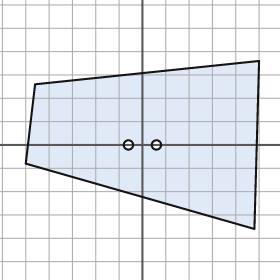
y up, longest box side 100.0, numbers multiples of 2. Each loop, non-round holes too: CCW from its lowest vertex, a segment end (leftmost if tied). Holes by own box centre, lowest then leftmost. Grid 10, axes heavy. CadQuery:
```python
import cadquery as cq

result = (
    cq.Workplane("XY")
    .moveTo(48.0, -36.0)
    .lineTo(50.0, 36.0)
    .lineTo(-46.0, 26.0)
    .lineTo(-50.0, -8.0)
    .close()
    .moveTo(-6.0, 0.0)
    .circle(2.0)
    .moveTo(6.0, 0.0)
    .circle(2.0)
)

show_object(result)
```